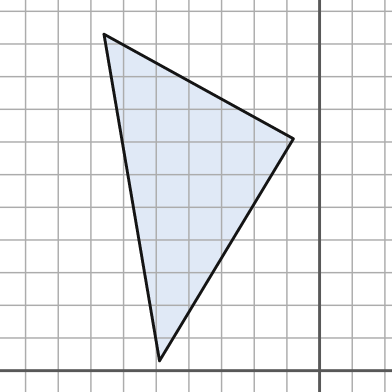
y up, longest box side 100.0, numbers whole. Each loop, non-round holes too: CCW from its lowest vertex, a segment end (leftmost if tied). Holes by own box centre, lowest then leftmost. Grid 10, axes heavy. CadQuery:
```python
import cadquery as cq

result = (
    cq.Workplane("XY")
    .moveTo(-49.0, 3.0)
    .lineTo(-8.0, 71.0)
    .lineTo(-66.0, 103.0)
    .close()
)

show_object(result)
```